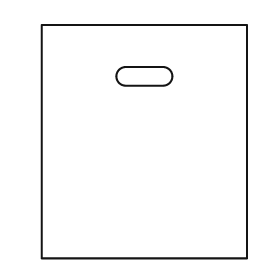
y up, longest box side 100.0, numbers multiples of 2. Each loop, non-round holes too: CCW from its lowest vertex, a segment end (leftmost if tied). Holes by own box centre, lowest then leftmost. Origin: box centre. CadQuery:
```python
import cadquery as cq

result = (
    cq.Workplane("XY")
    .moveTo(-44.0, -50.0)
    .lineTo(44.0, -50.0)
    .lineTo(44.0, 50.0)
    .lineTo(-44.0, 50.0)
    .close()
    .moveTo(-8.0, 24.0)
    .lineTo(8.0, 24.0)
    .threePointArc((12.0, 28.0), (8.0, 32.0))
    .lineTo(-8.0, 32.0)
    .threePointArc((-12.0, 28.0), (-8.0, 24.0))
    .close()
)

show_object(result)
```